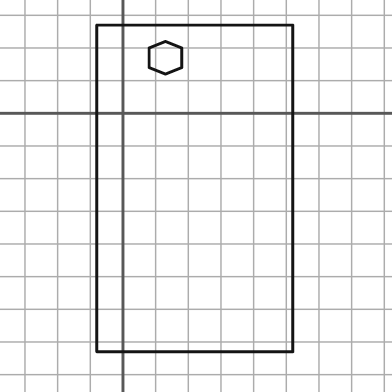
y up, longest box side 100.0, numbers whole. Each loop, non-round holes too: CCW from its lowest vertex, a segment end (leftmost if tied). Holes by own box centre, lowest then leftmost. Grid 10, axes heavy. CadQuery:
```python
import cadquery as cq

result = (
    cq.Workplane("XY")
    .moveTo(-8.0, -73.0)
    .lineTo(52.0, -73.0)
    .lineTo(52.0, 27.0)
    .lineTo(-8.0, 27.0)
    .close()
    .moveTo(13.0, 12.0)
    .lineTo(18.0, 14.0)
    .lineTo(18.0, 20.0)
    .lineTo(13.0, 22.0)
    .lineTo(8.0, 20.0)
    .lineTo(8.0, 14.0)
    .close()
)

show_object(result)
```